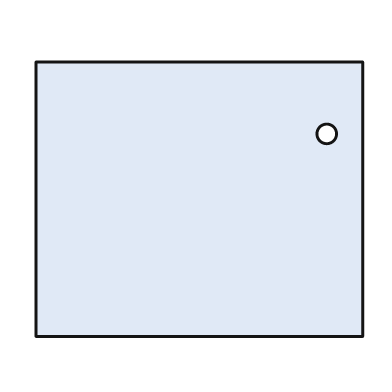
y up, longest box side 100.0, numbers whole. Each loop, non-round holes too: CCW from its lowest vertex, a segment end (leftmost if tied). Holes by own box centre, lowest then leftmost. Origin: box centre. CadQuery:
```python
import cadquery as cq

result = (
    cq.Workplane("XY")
    .moveTo(-50.0, -42.0)
    .lineTo(50.0, -42.0)
    .lineTo(50.0, 42.0)
    .lineTo(-50.0, 42.0)
    .close()
    .moveTo(39.0, 20.0)
    .circle(3.0)
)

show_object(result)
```